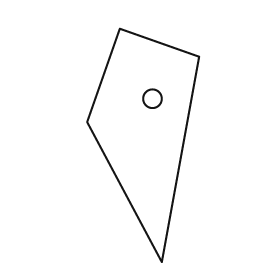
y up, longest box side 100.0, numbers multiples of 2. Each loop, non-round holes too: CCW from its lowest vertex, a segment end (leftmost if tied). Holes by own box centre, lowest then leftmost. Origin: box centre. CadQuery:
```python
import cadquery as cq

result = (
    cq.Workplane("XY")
    .moveTo(8.0, -50.0)
    .lineTo(24.0, 38.0)
    .lineTo(-10.0, 50.0)
    .lineTo(-24.0, 10.0)
    .close()
    .moveTo(4.0, 20.0)
    .circle(4.0)
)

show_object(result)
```